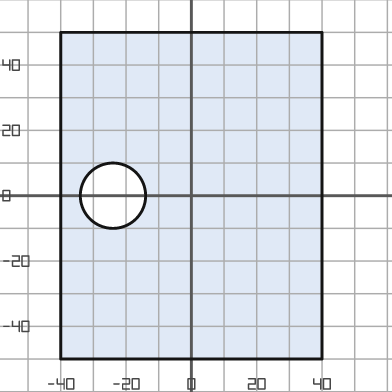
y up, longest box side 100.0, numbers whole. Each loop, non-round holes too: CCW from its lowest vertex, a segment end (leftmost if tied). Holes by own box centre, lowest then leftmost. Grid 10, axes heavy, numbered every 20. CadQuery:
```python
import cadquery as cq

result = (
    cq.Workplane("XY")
    .moveTo(-40.0, -50.0)
    .lineTo(40.0, -50.0)
    .lineTo(40.0, 50.0)
    .lineTo(-40.0, 50.0)
    .close()
    .moveTo(-24.0, 0.0)
    .circle(10.0)
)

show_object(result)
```